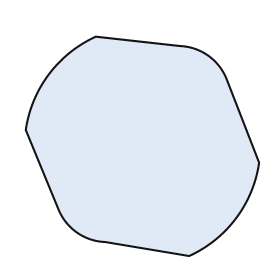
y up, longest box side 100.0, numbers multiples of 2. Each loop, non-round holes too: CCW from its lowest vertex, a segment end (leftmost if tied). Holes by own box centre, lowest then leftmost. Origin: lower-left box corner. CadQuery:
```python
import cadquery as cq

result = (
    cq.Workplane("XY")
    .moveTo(70.0, 0.0)
    .threePointArc((90.0, 16.0), (100.0, 40.0))
    .lineTo(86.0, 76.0)
    .threePointArc((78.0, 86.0), (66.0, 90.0))
    .lineTo(30.0, 94.0)
    .threePointArc((10.0, 78.0), (0.0, 54.0))
    .lineTo(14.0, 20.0)
    .threePointArc((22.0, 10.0), (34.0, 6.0))
    .close()
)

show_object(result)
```